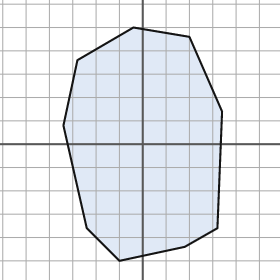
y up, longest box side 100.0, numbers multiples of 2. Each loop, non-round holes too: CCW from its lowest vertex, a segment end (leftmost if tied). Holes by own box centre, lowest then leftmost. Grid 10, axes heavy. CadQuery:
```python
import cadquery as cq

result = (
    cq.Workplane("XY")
    .moveTo(-10.0, -50.0)
    .lineTo(18.0, -44.0)
    .lineTo(32.0, -36.0)
    .lineTo(34.0, 14.0)
    .lineTo(20.0, 46.0)
    .lineTo(-4.0, 50.0)
    .lineTo(-28.0, 36.0)
    .lineTo(-34.0, 8.0)
    .lineTo(-24.0, -36.0)
    .close()
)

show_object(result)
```